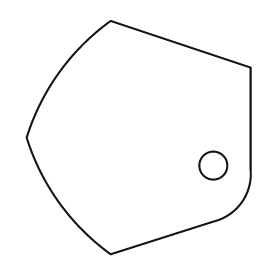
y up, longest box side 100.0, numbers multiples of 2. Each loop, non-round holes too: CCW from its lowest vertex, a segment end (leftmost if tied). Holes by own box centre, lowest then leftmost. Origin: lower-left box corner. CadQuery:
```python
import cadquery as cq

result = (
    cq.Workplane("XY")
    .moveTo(36.0, 0.0)
    .lineTo(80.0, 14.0)
    .threePointArc((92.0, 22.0), (96.0, 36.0))
    .lineTo(96.0, 80.0)
    .lineTo(36.0, 100.0)
    .threePointArc((14.0, 78.0), (0.0, 50.0))
    .threePointArc((14.0, 22.0), (36.0, 0.0))
    .close()
    .moveTo(80.0, 38.0)
    .circle(6.0)
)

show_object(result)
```